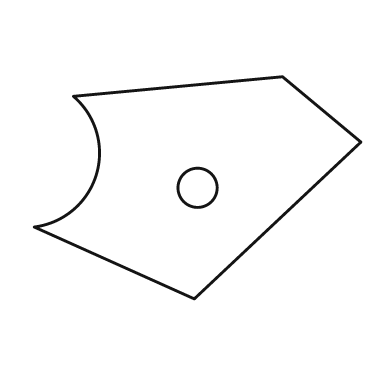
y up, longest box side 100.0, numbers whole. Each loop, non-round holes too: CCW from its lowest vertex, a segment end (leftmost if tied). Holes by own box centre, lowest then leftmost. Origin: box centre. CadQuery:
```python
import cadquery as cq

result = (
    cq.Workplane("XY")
    .moveTo(-1.0, -34.0)
    .lineTo(50.0, 14.0)
    .lineTo(26.0, 34.0)
    .lineTo(-38.0, 28.0)
    .threePointArc((-31.0, 4.0), (-50.0, -12.0))
    .close()
    .moveTo(0.0, 0.0)
    .circle(6.0)
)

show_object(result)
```